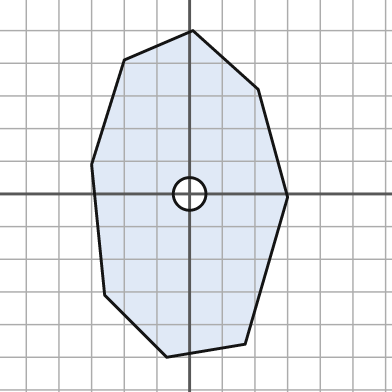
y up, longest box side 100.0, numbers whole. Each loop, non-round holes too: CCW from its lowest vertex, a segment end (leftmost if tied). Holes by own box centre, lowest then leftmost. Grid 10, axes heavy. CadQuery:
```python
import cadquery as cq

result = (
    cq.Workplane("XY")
    .moveTo(-7.0, -50.0)
    .lineTo(17.0, -46.0)
    .lineTo(30.0, -1.0)
    .lineTo(21.0, 32.0)
    .lineTo(1.0, 50.0)
    .lineTo(-20.0, 41.0)
    .lineTo(-30.0, 9.0)
    .lineTo(-26.0, -31.0)
    .close()
    .moveTo(0.0, 0.0)
    .circle(5.0)
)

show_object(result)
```